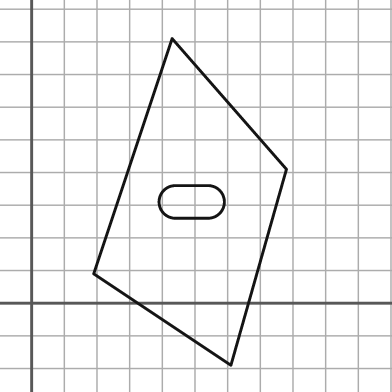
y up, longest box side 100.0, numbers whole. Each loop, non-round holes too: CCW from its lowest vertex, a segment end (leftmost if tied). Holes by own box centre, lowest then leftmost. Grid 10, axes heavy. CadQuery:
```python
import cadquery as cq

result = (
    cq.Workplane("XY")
    .moveTo(61.0, -19.0)
    .lineTo(78.0, 41.0)
    .lineTo(43.0, 81.0)
    .lineTo(19.0, 9.0)
    .close()
    .moveTo(44.0, 26.0)
    .lineTo(54.0, 26.0)
    .threePointArc((59.0, 31.0), (54.0, 36.0))
    .lineTo(44.0, 36.0)
    .threePointArc((39.0, 31.0), (44.0, 26.0))
    .close()
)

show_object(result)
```